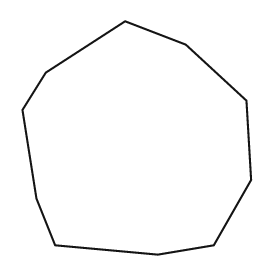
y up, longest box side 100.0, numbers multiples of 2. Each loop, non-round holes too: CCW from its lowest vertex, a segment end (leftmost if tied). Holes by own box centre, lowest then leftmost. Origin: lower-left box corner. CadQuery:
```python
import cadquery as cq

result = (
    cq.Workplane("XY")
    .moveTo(58.0, 0.0)
    .lineTo(82.0, 4.0)
    .lineTo(98.0, 32.0)
    .lineTo(96.0, 66.0)
    .lineTo(70.0, 90.0)
    .lineTo(44.0, 100.0)
    .lineTo(10.0, 78.0)
    .lineTo(0.0, 62.0)
    .lineTo(6.0, 24.0)
    .lineTo(14.0, 4.0)
    .close()
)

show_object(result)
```